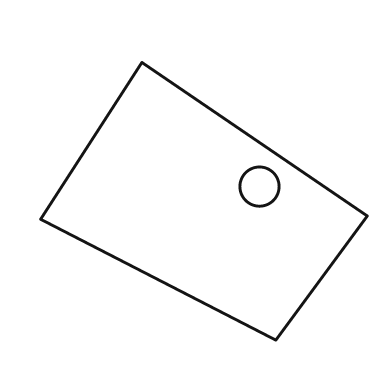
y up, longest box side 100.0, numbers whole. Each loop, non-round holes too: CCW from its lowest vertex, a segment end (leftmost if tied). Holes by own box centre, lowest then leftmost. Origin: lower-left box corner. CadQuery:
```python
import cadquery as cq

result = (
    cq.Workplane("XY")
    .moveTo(72.0, 0.0)
    .lineTo(100.0, 38.0)
    .lineTo(31.0, 85.0)
    .lineTo(0.0, 37.0)
    .close()
    .moveTo(67.0, 47.0)
    .circle(6.0)
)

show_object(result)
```